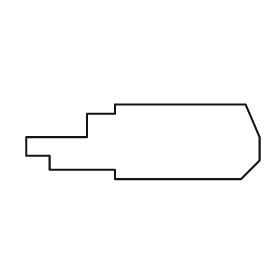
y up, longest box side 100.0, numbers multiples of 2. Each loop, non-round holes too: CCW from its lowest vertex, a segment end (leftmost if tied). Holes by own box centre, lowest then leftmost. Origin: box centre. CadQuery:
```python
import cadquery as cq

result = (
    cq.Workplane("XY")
    .moveTo(-12.0, -16.0)
    .lineTo(42.0, -16.0)
    .lineTo(50.0, -8.0)
    .lineTo(50.0, 2.0)
    .lineTo(44.0, 16.0)
    .lineTo(-12.0, 16.0)
    .lineTo(-12.0, 12.0)
    .lineTo(-24.0, 12.0)
    .lineTo(-24.0, 2.0)
    .lineTo(-50.0, 2.0)
    .lineTo(-50.0, -6.0)
    .lineTo(-40.0, -6.0)
    .lineTo(-40.0, -12.0)
    .lineTo(-12.0, -12.0)
    .close()
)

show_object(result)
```